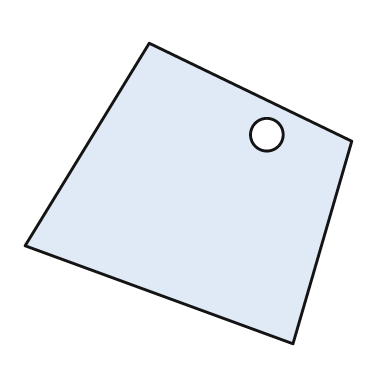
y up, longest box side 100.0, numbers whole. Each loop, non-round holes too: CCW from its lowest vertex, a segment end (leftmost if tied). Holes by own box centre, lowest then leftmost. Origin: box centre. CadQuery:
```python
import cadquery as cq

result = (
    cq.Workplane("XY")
    .moveTo(32.0, -46.0)
    .lineTo(50.0, 16.0)
    .lineTo(-12.0, 46.0)
    .lineTo(-50.0, -16.0)
    .close()
    .moveTo(24.0, 18.0)
    .circle(5.0)
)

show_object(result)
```